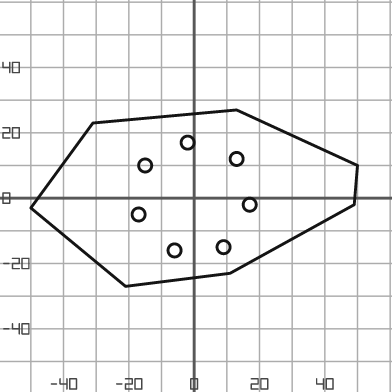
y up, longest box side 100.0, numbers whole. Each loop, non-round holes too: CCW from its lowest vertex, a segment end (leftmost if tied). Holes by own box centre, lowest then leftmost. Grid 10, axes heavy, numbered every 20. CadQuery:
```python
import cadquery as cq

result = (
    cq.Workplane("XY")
    .moveTo(-21.0, -27.0)
    .lineTo(11.0, -23.0)
    .lineTo(49.0, -2.0)
    .lineTo(50.0, 10.0)
    .lineTo(13.0, 27.0)
    .lineTo(-31.0, 23.0)
    .lineTo(-50.0, -3.0)
    .close()
    .moveTo(-6.0, -16.0)
    .circle(2.0)
    .moveTo(9.0, -15.0)
    .circle(2.0)
    .moveTo(-17.0, -5.0)
    .circle(2.0)
    .moveTo(17.0, -2.0)
    .circle(2.0)
    .moveTo(-15.0, 10.0)
    .circle(2.0)
    .moveTo(13.0, 12.0)
    .circle(2.0)
    .moveTo(-2.0, 17.0)
    .circle(2.0)
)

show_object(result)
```